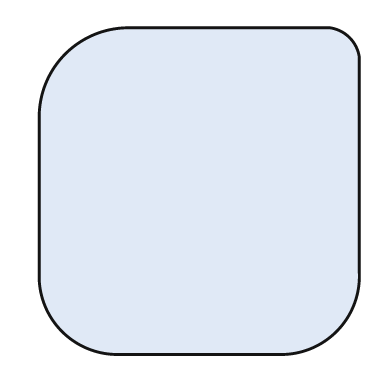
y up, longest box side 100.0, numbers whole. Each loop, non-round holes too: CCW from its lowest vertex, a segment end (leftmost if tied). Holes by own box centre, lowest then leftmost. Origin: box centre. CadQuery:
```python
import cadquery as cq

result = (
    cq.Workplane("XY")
    .moveTo(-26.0, -50.0)
    .lineTo(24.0, -50.0)
    .threePointArc((42.0, -43.0), (49.0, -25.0))
    .lineTo(49.0, 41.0)
    .threePointArc((46.0, 47.0), (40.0, 50.0))
    .lineTo(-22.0, 50.0)
    .threePointArc((-41.0, 42.0), (-49.0, 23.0))
    .lineTo(-49.0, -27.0)
    .threePointArc((-42.0, -43.0), (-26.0, -50.0))
    .close()
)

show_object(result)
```